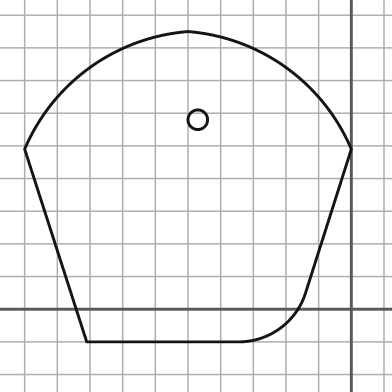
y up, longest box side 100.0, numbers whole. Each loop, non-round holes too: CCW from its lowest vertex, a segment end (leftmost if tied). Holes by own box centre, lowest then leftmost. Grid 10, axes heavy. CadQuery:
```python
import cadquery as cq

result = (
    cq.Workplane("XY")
    .moveTo(-81.0, -10.0)
    .lineTo(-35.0, -10.0)
    .threePointArc((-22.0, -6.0), (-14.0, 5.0))
    .lineTo(0.0, 49.0)
    .threePointArc((-20.0, 74.0), (-50.0, 85.0))
    .threePointArc((-80.0, 74.0), (-100.0, 49.0))
    .close()
    .moveTo(-47.0, 58.0)
    .circle(3.0)
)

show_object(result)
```